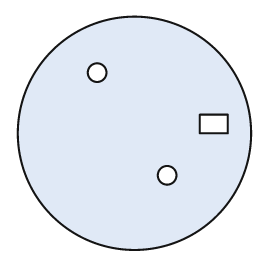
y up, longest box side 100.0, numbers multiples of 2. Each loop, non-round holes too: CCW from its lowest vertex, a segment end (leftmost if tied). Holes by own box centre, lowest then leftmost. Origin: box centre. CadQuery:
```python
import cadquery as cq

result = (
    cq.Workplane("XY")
    .moveTo(0.0, 0.0)
    .circle(50.0)
    .moveTo(14.0, -18.0)
    .circle(4.0)
    .moveTo(28.0, 0.0)
    .lineTo(40.0, 0.0)
    .lineTo(40.0, 8.0)
    .lineTo(28.0, 8.0)
    .close()
    .moveTo(-16.0, 26.0)
    .circle(4.0)
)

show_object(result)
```